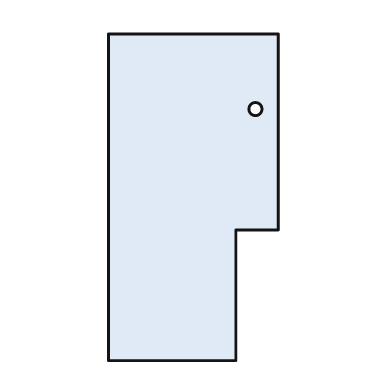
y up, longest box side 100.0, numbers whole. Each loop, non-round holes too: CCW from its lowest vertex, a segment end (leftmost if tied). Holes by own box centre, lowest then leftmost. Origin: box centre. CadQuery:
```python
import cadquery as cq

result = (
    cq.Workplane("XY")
    .moveTo(-26.0, -50.0)
    .lineTo(13.0, -50.0)
    .lineTo(13.0, -10.0)
    .lineTo(26.0, -10.0)
    .lineTo(26.0, 50.0)
    .lineTo(-26.0, 50.0)
    .close()
    .moveTo(19.0, 27.0)
    .circle(2.0)
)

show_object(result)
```